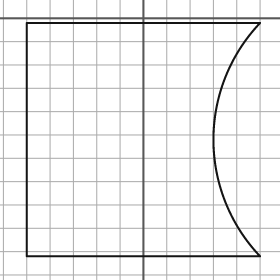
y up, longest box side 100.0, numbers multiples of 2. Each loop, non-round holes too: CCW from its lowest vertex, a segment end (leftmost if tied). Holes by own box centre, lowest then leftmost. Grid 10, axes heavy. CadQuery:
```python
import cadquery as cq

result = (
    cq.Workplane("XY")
    .moveTo(-50.0, -102.0)
    .lineTo(50.0, -102.0)
    .threePointArc((30.0, -52.0), (50.0, -2.0))
    .lineTo(-50.0, -2.0)
    .close()
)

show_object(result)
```